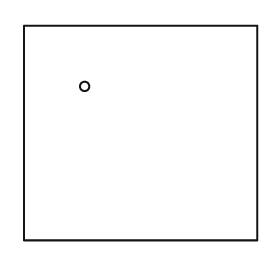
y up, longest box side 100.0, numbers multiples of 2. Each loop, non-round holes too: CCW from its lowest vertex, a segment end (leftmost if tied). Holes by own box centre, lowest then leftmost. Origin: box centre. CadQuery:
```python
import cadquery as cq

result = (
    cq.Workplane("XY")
    .moveTo(-50.0, -46.0)
    .lineTo(50.0, -46.0)
    .lineTo(50.0, 46.0)
    .lineTo(-50.0, 46.0)
    .close()
    .moveTo(-24.0, 20.0)
    .circle(2.0)
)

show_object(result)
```